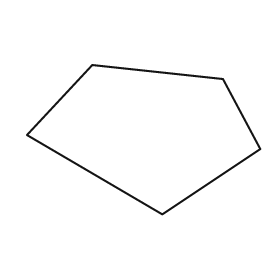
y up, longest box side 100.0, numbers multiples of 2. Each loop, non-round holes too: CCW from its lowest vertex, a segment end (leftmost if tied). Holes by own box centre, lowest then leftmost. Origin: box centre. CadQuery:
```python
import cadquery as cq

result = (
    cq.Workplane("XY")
    .moveTo(8.0, -32.0)
    .lineTo(50.0, -4.0)
    .lineTo(34.0, 26.0)
    .lineTo(-22.0, 32.0)
    .lineTo(-50.0, 2.0)
    .close()
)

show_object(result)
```